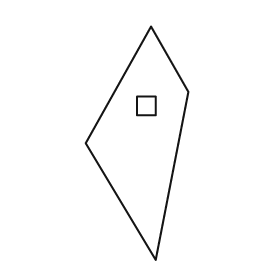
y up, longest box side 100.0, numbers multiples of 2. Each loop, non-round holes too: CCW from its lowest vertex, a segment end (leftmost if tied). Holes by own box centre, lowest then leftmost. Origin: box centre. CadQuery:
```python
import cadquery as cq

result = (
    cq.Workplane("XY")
    .moveTo(8.0, -50.0)
    .lineTo(22.0, 22.0)
    .lineTo(6.0, 50.0)
    .lineTo(-22.0, 0.0)
    .close()
    .moveTo(0.0, 12.0)
    .lineTo(8.0, 12.0)
    .lineTo(8.0, 20.0)
    .lineTo(0.0, 20.0)
    .close()
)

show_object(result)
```